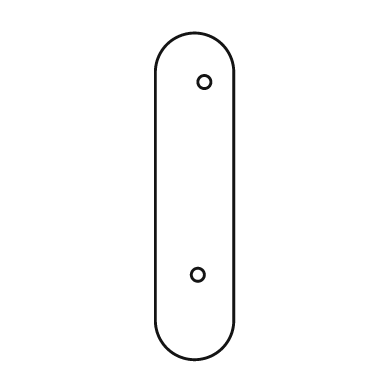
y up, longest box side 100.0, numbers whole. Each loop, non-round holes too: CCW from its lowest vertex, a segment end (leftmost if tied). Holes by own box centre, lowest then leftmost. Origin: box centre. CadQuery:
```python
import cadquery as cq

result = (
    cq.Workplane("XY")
    .moveTo(-12.0, -38.0)
    .threePointArc((0.0, -50.0), (12.0, -38.0))
    .lineTo(12.0, 38.0)
    .threePointArc((0.0, 50.0), (-12.0, 38.0))
    .close()
    .moveTo(1.0, -24.0)
    .circle(2.0)
    .moveTo(3.0, 35.0)
    .circle(2.0)
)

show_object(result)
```